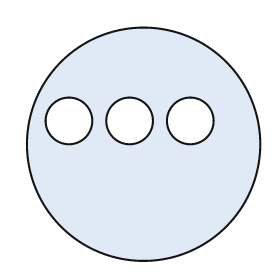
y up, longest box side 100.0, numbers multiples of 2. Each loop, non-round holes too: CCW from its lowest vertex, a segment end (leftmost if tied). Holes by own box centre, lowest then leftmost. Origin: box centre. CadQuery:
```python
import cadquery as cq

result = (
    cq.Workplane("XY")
    .moveTo(0.0, 0.0)
    .circle(50.0)
    .moveTo(-32.0, 10.0)
    .circle(10.0)
    .moveTo(-6.0, 10.0)
    .circle(10.0)
    .moveTo(20.0, 10.0)
    .circle(10.0)
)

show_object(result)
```